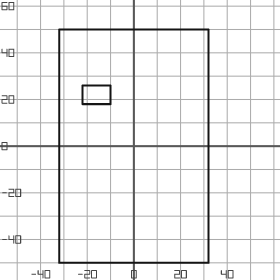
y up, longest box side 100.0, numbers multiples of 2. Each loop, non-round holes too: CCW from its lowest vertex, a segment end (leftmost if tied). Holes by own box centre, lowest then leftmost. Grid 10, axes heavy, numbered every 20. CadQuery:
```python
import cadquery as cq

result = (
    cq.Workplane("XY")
    .moveTo(-32.0, -50.0)
    .lineTo(32.0, -50.0)
    .lineTo(32.0, 50.0)
    .lineTo(-32.0, 50.0)
    .close()
    .moveTo(-22.0, 18.0)
    .lineTo(-10.0, 18.0)
    .lineTo(-10.0, 26.0)
    .lineTo(-22.0, 26.0)
    .close()
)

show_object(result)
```